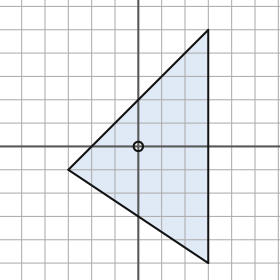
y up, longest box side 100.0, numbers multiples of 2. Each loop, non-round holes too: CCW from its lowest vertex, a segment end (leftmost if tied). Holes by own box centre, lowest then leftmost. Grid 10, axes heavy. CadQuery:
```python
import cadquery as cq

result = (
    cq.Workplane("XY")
    .moveTo(30.0, -50.0)
    .lineTo(30.0, 50.0)
    .lineTo(-30.0, -10.0)
    .close()
    .moveTo(0.0, 0.0)
    .circle(2.0)
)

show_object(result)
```